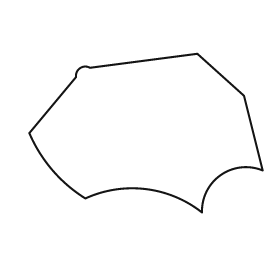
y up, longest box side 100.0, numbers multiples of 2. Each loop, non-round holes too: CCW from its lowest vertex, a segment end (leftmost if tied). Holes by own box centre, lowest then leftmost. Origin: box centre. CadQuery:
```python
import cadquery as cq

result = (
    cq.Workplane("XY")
    .moveTo(24.0, -34.0)
    .threePointArc((32.0, -18.0), (50.0, -16.0))
    .lineTo(42.0, 16.0)
    .lineTo(22.0, 34.0)
    .lineTo(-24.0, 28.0)
    .threePointArc((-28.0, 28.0), (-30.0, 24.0))
    .lineTo(-50.0, 0.0)
    .threePointArc((-40.0, -16.0), (-26.0, -28.0))
    .threePointArc((0.0, -24.0), (24.0, -34.0))
    .close()
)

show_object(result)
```